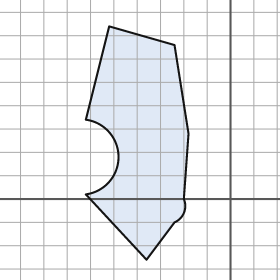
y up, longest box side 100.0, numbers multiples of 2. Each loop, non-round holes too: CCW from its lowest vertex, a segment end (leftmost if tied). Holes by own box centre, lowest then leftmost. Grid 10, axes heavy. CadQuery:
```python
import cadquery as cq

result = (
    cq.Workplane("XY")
    .moveTo(-36.0, -26.0)
    .lineTo(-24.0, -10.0)
    .threePointArc((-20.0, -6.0), (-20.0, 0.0))
    .lineTo(-18.0, 28.0)
    .lineTo(-24.0, 66.0)
    .lineTo(-52.0, 74.0)
    .lineTo(-62.0, 34.0)
    .threePointArc((-48.0, 18.0), (-62.0, 2.0))
    .close()
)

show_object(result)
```